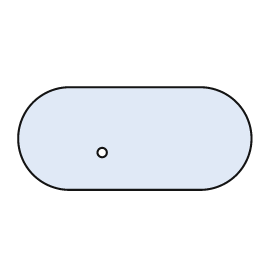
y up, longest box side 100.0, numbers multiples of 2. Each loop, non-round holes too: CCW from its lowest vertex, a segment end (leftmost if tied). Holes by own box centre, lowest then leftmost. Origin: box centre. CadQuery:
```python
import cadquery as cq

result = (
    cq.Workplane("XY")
    .moveTo(-28.0, -22.0)
    .lineTo(28.0, -22.0)
    .threePointArc((50.0, 0.0), (28.0, 22.0))
    .lineTo(-28.0, 22.0)
    .threePointArc((-50.0, 0.0), (-28.0, -22.0))
    .close()
    .moveTo(-14.0, -6.0)
    .circle(2.0)
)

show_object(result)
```